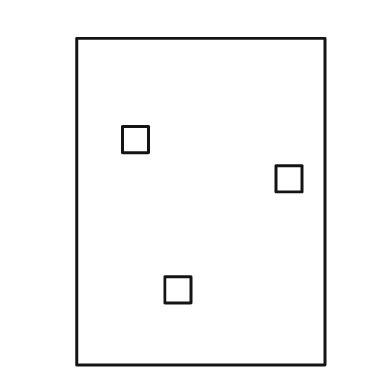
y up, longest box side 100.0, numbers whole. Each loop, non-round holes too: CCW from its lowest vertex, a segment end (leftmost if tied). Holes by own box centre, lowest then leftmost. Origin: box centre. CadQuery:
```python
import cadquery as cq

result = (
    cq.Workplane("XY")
    .moveTo(-38.0, -50.0)
    .lineTo(38.0, -50.0)
    .lineTo(38.0, 50.0)
    .lineTo(-38.0, 50.0)
    .close()
    .moveTo(-11.0, -31.0)
    .lineTo(-3.0, -31.0)
    .lineTo(-3.0, -23.0)
    .lineTo(-11.0, -23.0)
    .close()
    .moveTo(23.0, 3.0)
    .lineTo(31.0, 3.0)
    .lineTo(31.0, 11.0)
    .lineTo(23.0, 11.0)
    .close()
    .moveTo(-24.0, 15.0)
    .lineTo(-16.0, 15.0)
    .lineTo(-16.0, 23.0)
    .lineTo(-24.0, 23.0)
    .close()
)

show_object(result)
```